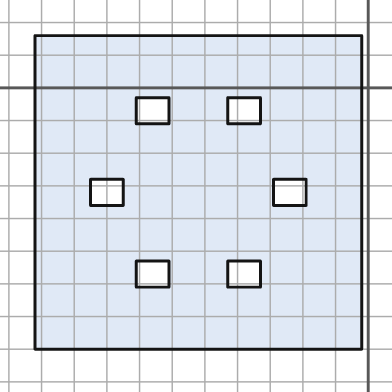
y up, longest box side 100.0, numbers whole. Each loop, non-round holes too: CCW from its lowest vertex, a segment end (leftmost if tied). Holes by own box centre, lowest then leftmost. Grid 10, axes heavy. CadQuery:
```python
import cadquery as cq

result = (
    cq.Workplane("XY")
    .moveTo(-102.0, -80.0)
    .lineTo(-2.0, -80.0)
    .lineTo(-2.0, 16.0)
    .lineTo(-102.0, 16.0)
    .close()
    .moveTo(-71.0, -61.0)
    .lineTo(-61.0, -61.0)
    .lineTo(-61.0, -53.0)
    .lineTo(-71.0, -53.0)
    .close()
    .moveTo(-43.0, -61.0)
    .lineTo(-33.0, -61.0)
    .lineTo(-33.0, -53.0)
    .lineTo(-43.0, -53.0)
    .close()
    .moveTo(-85.0, -36.0)
    .lineTo(-75.0, -36.0)
    .lineTo(-75.0, -28.0)
    .lineTo(-85.0, -28.0)
    .close()
    .moveTo(-29.0, -36.0)
    .lineTo(-19.0, -36.0)
    .lineTo(-19.0, -28.0)
    .lineTo(-29.0, -28.0)
    .close()
    .moveTo(-71.0, -11.0)
    .lineTo(-61.0, -11.0)
    .lineTo(-61.0, -3.0)
    .lineTo(-71.0, -3.0)
    .close()
    .moveTo(-43.0, -11.0)
    .lineTo(-33.0, -11.0)
    .lineTo(-33.0, -3.0)
    .lineTo(-43.0, -3.0)
    .close()
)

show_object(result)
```